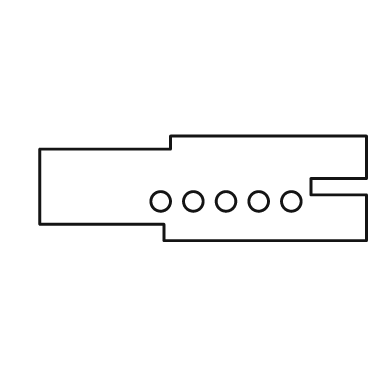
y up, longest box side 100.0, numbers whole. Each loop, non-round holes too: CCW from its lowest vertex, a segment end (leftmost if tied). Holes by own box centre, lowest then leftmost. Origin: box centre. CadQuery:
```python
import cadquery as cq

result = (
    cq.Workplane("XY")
    .moveTo(-12.0, -16.0)
    .lineTo(50.0, -16.0)
    .lineTo(50.0, -2.0)
    .lineTo(33.0, -2.0)
    .lineTo(33.0, 3.0)
    .lineTo(50.0, 3.0)
    .lineTo(50.0, 16.0)
    .lineTo(-10.0, 16.0)
    .lineTo(-10.0, 12.0)
    .lineTo(-50.0, 12.0)
    .lineTo(-50.0, -11.0)
    .lineTo(-12.0, -11.0)
    .close()
    .moveTo(-13.0, -4.0)
    .circle(3.0)
    .moveTo(-3.0, -4.0)
    .circle(3.0)
    .moveTo(7.0, -4.0)
    .circle(3.0)
    .moveTo(17.0, -4.0)
    .circle(3.0)
    .moveTo(27.0, -4.0)
    .circle(3.0)
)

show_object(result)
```